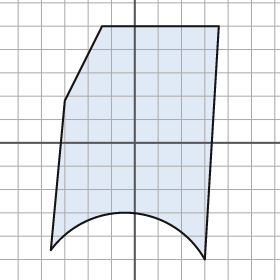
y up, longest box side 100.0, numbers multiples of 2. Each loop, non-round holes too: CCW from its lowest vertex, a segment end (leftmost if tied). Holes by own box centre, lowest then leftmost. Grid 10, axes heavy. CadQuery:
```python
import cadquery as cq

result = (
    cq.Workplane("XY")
    .moveTo(30.0, -50.0)
    .lineTo(36.0, 50.0)
    .lineTo(-14.0, 50.0)
    .lineTo(-30.0, 18.0)
    .lineTo(-36.0, -46.0)
    .threePointArc((-2.0, -30.0), (30.0, -50.0))
    .close()
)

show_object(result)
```